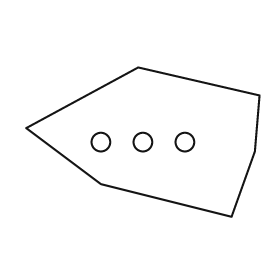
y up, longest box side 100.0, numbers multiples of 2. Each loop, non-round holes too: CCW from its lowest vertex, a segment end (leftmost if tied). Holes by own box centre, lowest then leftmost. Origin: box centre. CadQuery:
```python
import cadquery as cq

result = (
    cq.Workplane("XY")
    .moveTo(38.0, -32.0)
    .lineTo(48.0, -4.0)
    .lineTo(50.0, 20.0)
    .lineTo(-2.0, 32.0)
    .lineTo(-50.0, 6.0)
    .lineTo(-18.0, -18.0)
    .close()
    .moveTo(-18.0, 0.0)
    .circle(4.0)
    .moveTo(0.0, 0.0)
    .circle(4.0)
    .moveTo(18.0, 0.0)
    .circle(4.0)
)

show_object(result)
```